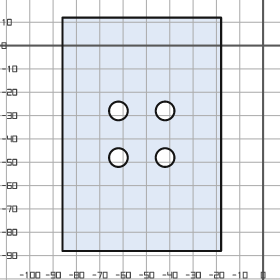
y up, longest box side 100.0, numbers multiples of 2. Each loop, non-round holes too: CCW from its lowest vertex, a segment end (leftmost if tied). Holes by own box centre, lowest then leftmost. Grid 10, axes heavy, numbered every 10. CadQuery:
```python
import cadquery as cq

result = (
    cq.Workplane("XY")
    .moveTo(-86.0, -88.0)
    .lineTo(-18.0, -88.0)
    .lineTo(-18.0, 12.0)
    .lineTo(-86.0, 12.0)
    .close()
    .moveTo(-62.0, -48.0)
    .circle(4.0)
    .moveTo(-42.0, -48.0)
    .circle(4.0)
    .moveTo(-62.0, -28.0)
    .circle(4.0)
    .moveTo(-42.0, -28.0)
    .circle(4.0)
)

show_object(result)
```